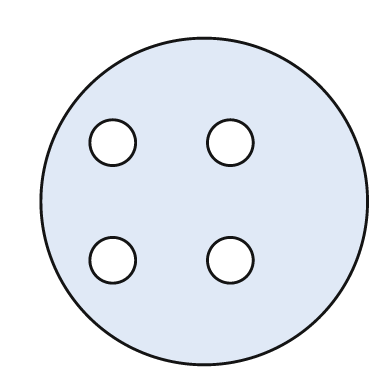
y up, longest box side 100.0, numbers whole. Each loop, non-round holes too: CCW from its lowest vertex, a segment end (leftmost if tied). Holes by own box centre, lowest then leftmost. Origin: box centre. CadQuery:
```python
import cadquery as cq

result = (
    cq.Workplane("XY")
    .moveTo(0.0, 0.0)
    .circle(50.0)
    .moveTo(-28.0, -18.0)
    .circle(7.0)
    .moveTo(8.0, -18.0)
    .circle(7.0)
    .moveTo(-28.0, 18.0)
    .circle(7.0)
    .moveTo(8.0, 18.0)
    .circle(7.0)
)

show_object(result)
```